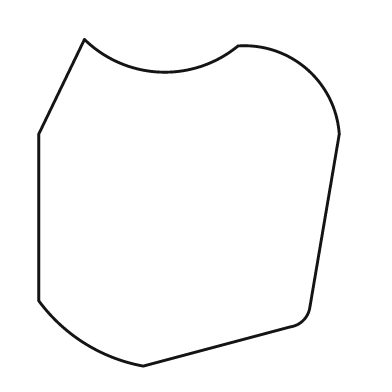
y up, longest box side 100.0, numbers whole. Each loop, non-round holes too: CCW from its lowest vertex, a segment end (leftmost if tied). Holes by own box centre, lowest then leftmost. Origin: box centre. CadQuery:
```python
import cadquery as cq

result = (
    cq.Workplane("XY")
    .moveTo(-14.0, -50.0)
    .lineTo(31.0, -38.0)
    .threePointArc((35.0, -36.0), (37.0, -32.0))
    .lineTo(46.0, 21.0)
    .threePointArc((36.0, 41.0), (15.0, 48.0))
    .threePointArc((-9.0, 40.0), (-32.0, 50.0))
    .lineTo(-46.0, 21.0)
    .lineTo(-46.0, -30.0)
    .threePointArc((-32.0, -43.0), (-14.0, -50.0))
    .close()
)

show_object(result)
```